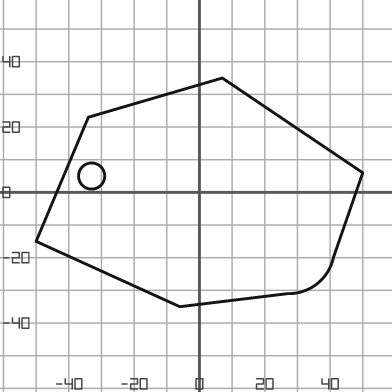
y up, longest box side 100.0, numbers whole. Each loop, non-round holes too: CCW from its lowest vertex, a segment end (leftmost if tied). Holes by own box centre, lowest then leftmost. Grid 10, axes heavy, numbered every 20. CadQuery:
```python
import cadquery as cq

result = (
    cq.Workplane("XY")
    .moveTo(-6.0, -35.0)
    .lineTo(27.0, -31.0)
    .threePointArc((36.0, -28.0), (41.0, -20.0))
    .lineTo(50.0, 6.0)
    .lineTo(7.0, 35.0)
    .lineTo(-34.0, 23.0)
    .lineTo(-50.0, -15.0)
    .close()
    .moveTo(-33.0, 5.0)
    .circle(4.0)
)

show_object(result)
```